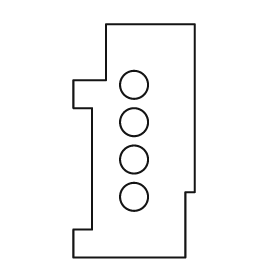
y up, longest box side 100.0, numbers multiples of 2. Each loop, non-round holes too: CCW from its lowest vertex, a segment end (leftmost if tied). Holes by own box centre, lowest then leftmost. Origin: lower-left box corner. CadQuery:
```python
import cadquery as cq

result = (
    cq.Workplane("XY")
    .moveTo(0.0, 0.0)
    .lineTo(48.0, 0.0)
    .lineTo(48.0, 28.0)
    .lineTo(52.0, 28.0)
    .lineTo(52.0, 100.0)
    .lineTo(14.0, 100.0)
    .lineTo(14.0, 76.0)
    .lineTo(0.0, 76.0)
    .lineTo(0.0, 64.0)
    .lineTo(8.0, 64.0)
    .lineTo(8.0, 12.0)
    .lineTo(0.0, 12.0)
    .close()
    .moveTo(26.0, 26.0)
    .circle(6.0)
    .moveTo(26.0, 42.0)
    .circle(6.0)
    .moveTo(26.0, 58.0)
    .circle(6.0)
    .moveTo(26.0, 74.0)
    .circle(6.0)
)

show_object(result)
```